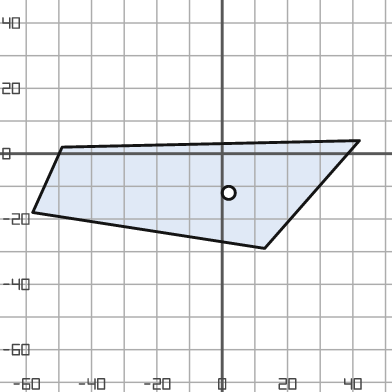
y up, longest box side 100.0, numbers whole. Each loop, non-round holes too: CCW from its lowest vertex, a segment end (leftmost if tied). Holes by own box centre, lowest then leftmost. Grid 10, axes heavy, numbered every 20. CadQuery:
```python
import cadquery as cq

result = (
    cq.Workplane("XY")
    .moveTo(13.0, -29.0)
    .lineTo(42.0, 4.0)
    .lineTo(-49.0, 2.0)
    .lineTo(-58.0, -18.0)
    .close()
    .moveTo(2.0, -12.0)
    .circle(2.0)
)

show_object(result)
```